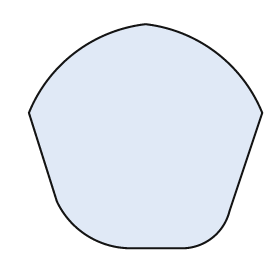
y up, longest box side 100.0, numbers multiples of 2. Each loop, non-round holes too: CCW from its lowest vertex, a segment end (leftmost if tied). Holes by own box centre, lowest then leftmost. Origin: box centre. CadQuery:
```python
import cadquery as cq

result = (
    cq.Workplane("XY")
    .moveTo(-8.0, -48.0)
    .lineTo(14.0, -48.0)
    .threePointArc((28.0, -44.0), (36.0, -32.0))
    .lineTo(50.0, 10.0)
    .threePointArc((30.0, 36.0), (0.0, 48.0))
    .threePointArc((-30.0, 36.0), (-50.0, 10.0))
    .lineTo(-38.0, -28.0)
    .threePointArc((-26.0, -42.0), (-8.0, -48.0))
    .close()
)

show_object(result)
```